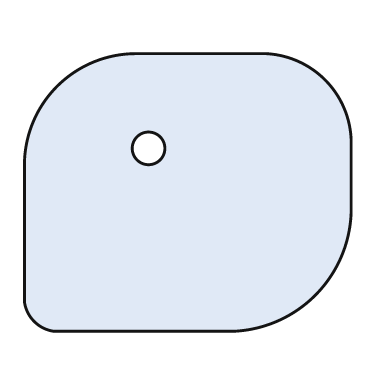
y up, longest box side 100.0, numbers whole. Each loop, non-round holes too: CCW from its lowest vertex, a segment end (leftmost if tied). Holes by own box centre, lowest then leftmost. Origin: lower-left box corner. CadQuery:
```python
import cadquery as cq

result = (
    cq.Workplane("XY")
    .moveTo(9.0, 0.0)
    .lineTo(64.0, 0.0)
    .threePointArc((89.0, 11.0), (100.0, 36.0))
    .lineTo(100.0, 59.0)
    .threePointArc((92.0, 77.0), (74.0, 85.0))
    .lineTo(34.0, 85.0)
    .threePointArc((10.0, 75.0), (0.0, 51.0))
    .lineTo(0.0, 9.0)
    .threePointArc((3.0, 3.0), (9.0, 0.0))
    .close()
    .moveTo(38.0, 56.0)
    .circle(5.0)
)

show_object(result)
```